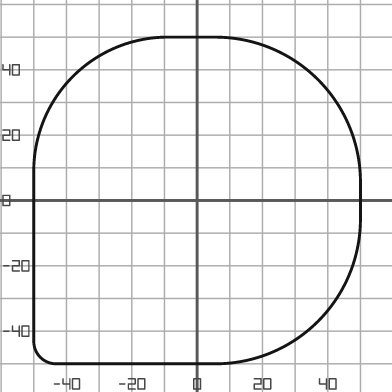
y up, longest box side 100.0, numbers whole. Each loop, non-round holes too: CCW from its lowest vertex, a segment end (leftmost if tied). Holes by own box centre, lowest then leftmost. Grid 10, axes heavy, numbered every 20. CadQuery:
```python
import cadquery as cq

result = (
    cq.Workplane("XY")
    .moveTo(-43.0, -50.0)
    .lineTo(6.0, -50.0)
    .threePointArc((37.0, -37.0), (50.0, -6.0))
    .lineTo(50.0, 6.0)
    .threePointArc((37.0, 37.0), (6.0, 50.0))
    .lineTo(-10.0, 50.0)
    .threePointArc((-38.0, 38.0), (-50.0, 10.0))
    .lineTo(-50.0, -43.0)
    .threePointArc((-48.0, -48.0), (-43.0, -50.0))
    .close()
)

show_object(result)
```